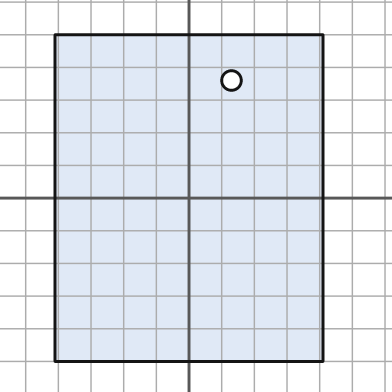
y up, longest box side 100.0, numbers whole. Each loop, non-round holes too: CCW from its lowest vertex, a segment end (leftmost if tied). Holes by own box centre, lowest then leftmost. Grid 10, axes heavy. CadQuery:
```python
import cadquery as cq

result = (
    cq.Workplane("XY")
    .moveTo(-41.0, -50.0)
    .lineTo(41.0, -50.0)
    .lineTo(41.0, 50.0)
    .lineTo(-41.0, 50.0)
    .close()
    .moveTo(13.0, 36.0)
    .circle(3.0)
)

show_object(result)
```